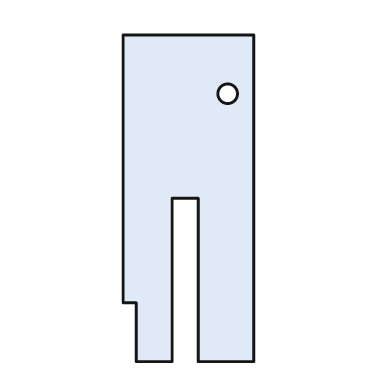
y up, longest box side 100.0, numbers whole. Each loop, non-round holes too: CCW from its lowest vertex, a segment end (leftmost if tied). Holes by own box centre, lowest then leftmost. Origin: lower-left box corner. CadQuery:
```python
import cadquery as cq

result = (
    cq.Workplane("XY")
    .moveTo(4.0, 0.0)
    .lineTo(15.0, 0.0)
    .lineTo(15.0, 50.0)
    .lineTo(23.0, 50.0)
    .lineTo(23.0, 0.0)
    .lineTo(40.0, 0.0)
    .lineTo(40.0, 100.0)
    .lineTo(0.0, 100.0)
    .lineTo(0.0, 18.0)
    .lineTo(4.0, 18.0)
    .close()
    .moveTo(32.0, 82.0)
    .circle(3.0)
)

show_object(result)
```